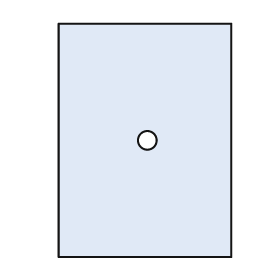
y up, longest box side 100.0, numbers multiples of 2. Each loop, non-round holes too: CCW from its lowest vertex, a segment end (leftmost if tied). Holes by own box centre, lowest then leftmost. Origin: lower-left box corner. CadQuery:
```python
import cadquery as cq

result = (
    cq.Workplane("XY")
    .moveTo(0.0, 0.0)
    .lineTo(74.0, 0.0)
    .lineTo(74.0, 100.0)
    .lineTo(0.0, 100.0)
    .close()
    .moveTo(38.0, 50.0)
    .circle(4.0)
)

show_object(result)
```